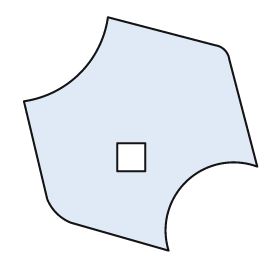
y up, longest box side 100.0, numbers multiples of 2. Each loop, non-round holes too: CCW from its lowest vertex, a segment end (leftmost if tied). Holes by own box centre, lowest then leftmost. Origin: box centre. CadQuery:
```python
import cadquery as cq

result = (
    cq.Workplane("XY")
    .moveTo(12.0, -50.0)
    .threePointArc((20.0, -20.0), (50.0, -14.0))
    .lineTo(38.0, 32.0)
    .threePointArc((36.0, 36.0), (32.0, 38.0))
    .lineTo(-14.0, 50.0)
    .threePointArc((-26.0, 26.0), (-50.0, 14.0))
    .lineTo(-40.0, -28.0)
    .threePointArc((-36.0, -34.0), (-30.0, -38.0))
    .close()
    .moveTo(-10.0, -16.0)
    .lineTo(2.0, -16.0)
    .lineTo(2.0, -4.0)
    .lineTo(-10.0, -4.0)
    .close()
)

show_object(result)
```